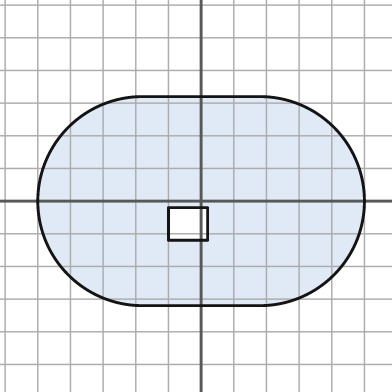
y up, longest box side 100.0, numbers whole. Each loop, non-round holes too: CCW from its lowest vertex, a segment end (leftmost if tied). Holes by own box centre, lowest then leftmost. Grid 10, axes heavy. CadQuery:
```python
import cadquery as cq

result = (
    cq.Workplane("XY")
    .moveTo(-18.0, -32.0)
    .lineTo(18.0, -32.0)
    .threePointArc((50.0, 0.0), (18.0, 32.0))
    .lineTo(-18.0, 32.0)
    .threePointArc((-50.0, 0.0), (-18.0, -32.0))
    .close()
    .moveTo(-10.0, -12.0)
    .lineTo(2.0, -12.0)
    .lineTo(2.0, -2.0)
    .lineTo(-10.0, -2.0)
    .close()
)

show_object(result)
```